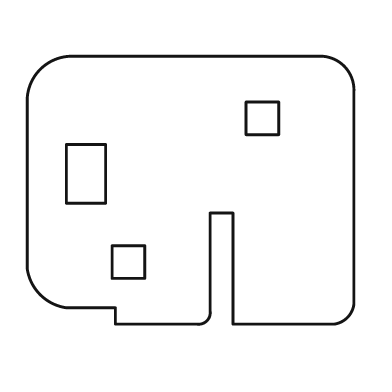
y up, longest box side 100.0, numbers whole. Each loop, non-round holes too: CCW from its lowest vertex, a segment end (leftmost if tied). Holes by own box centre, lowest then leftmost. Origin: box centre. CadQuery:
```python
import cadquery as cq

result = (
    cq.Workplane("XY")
    .moveTo(-23.0, -41.0)
    .lineTo(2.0, -41.0)
    .threePointArc((5.0, -40.0), (6.0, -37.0))
    .lineTo(6.0, -7.0)
    .lineTo(13.0, -7.0)
    .lineTo(13.0, -41.0)
    .lineTo(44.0, -41.0)
    .threePointArc((48.0, -39.0), (50.0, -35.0))
    .lineTo(50.0, 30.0)
    .threePointArc((47.0, 38.0), (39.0, 41.0))
    .lineTo(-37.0, 41.0)
    .threePointArc((-46.0, 37.0), (-50.0, 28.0))
    .lineTo(-50.0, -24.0)
    .threePointArc((-46.0, -32.0), (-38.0, -36.0))
    .lineTo(-23.0, -36.0)
    .close()
    .moveTo(-24.0, -27.0)
    .lineTo(-14.0, -27.0)
    .lineTo(-14.0, -17.0)
    .lineTo(-24.0, -17.0)
    .close()
    .moveTo(-38.0, -4.0)
    .lineTo(-26.0, -4.0)
    .lineTo(-26.0, 14.0)
    .lineTo(-38.0, 14.0)
    .close()
    .moveTo(17.0, 17.0)
    .lineTo(27.0, 17.0)
    .lineTo(27.0, 27.0)
    .lineTo(17.0, 27.0)
    .close()
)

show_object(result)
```